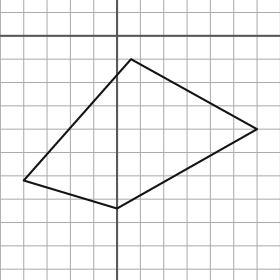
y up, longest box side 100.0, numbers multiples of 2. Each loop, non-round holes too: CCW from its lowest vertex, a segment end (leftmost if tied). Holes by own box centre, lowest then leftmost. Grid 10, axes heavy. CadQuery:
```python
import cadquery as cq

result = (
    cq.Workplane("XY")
    .moveTo(0.0, -74.0)
    .lineTo(60.0, -40.0)
    .lineTo(6.0, -10.0)
    .lineTo(-40.0, -62.0)
    .close()
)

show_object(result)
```